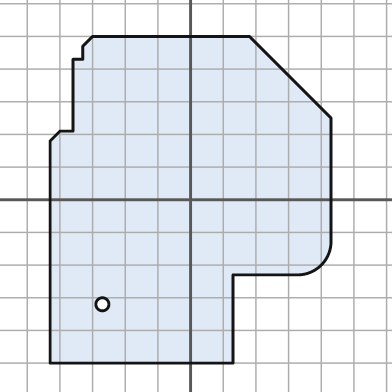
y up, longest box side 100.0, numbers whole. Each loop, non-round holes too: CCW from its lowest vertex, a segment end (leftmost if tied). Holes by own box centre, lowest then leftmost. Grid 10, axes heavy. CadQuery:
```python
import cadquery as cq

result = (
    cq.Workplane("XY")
    .moveTo(-43.0, -50.0)
    .lineTo(13.0, -50.0)
    .lineTo(13.0, -23.0)
    .lineTo(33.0, -23.0)
    .threePointArc((40.0, -20.0), (43.0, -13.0))
    .lineTo(43.0, 25.0)
    .lineTo(18.0, 50.0)
    .lineTo(-30.0, 50.0)
    .lineTo(-33.0, 47.0)
    .lineTo(-33.0, 43.0)
    .lineTo(-36.0, 43.0)
    .lineTo(-36.0, 21.0)
    .lineTo(-40.0, 21.0)
    .lineTo(-43.0, 18.0)
    .close()
    .moveTo(-27.0, -32.0)
    .circle(2.0)
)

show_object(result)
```